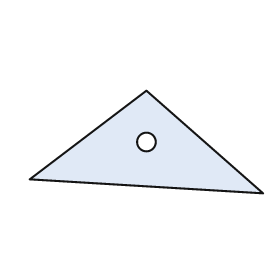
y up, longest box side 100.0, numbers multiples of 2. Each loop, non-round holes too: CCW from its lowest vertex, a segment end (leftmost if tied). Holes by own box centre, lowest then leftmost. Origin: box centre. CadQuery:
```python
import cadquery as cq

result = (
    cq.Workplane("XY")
    .moveTo(50.0, -22.0)
    .lineTo(0.0, 22.0)
    .lineTo(-50.0, -16.0)
    .close()
    .moveTo(0.0, 0.0)
    .circle(4.0)
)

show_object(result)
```